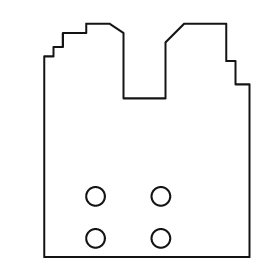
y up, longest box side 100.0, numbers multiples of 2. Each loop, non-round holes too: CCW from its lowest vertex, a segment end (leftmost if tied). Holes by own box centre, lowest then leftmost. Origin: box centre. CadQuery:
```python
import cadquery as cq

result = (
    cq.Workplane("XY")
    .moveTo(-44.0, -50.0)
    .lineTo(44.0, -50.0)
    .lineTo(44.0, 24.0)
    .lineTo(38.0, 24.0)
    .lineTo(38.0, 34.0)
    .lineTo(34.0, 34.0)
    .lineTo(34.0, 50.0)
    .lineTo(16.0, 50.0)
    .lineTo(8.0, 42.0)
    .lineTo(8.0, 18.0)
    .lineTo(-10.0, 18.0)
    .lineTo(-10.0, 46.0)
    .lineTo(-16.0, 50.0)
    .lineTo(-26.0, 50.0)
    .lineTo(-26.0, 46.0)
    .lineTo(-36.0, 46.0)
    .lineTo(-36.0, 40.0)
    .lineTo(-40.0, 40.0)
    .lineTo(-40.0, 36.0)
    .lineTo(-44.0, 36.0)
    .close()
    .moveTo(-22.0, -42.0)
    .circle(4.0)
    .moveTo(6.0, -42.0)
    .circle(4.0)
    .moveTo(-22.0, -24.0)
    .circle(4.0)
    .moveTo(6.0, -24.0)
    .circle(4.0)
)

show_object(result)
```